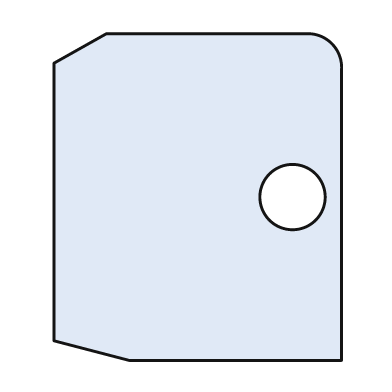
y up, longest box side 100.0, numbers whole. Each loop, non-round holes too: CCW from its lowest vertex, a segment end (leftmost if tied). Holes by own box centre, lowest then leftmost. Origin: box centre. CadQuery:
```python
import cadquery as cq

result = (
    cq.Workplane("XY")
    .moveTo(-21.0, -50.0)
    .lineTo(44.0, -50.0)
    .lineTo(44.0, 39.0)
    .threePointArc((41.0, 47.0), (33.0, 50.0))
    .lineTo(-28.0, 50.0)
    .lineTo(-44.0, 41.0)
    .lineTo(-44.0, -44.0)
    .close()
    .moveTo(29.0, 0.0)
    .circle(10.0)
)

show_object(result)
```